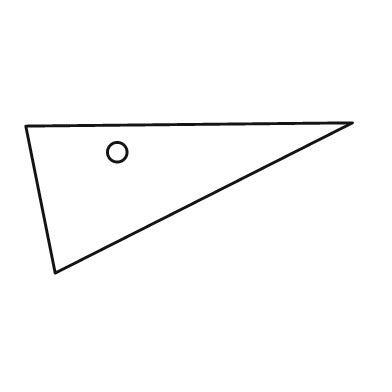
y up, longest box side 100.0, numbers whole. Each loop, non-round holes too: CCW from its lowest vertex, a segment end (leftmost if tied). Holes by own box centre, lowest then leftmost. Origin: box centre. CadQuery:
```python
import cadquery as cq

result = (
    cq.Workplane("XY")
    .moveTo(-41.0, -23.0)
    .lineTo(50.0, 23.0)
    .lineTo(-50.0, 22.0)
    .close()
    .moveTo(-22.0, 14.0)
    .circle(3.0)
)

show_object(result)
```